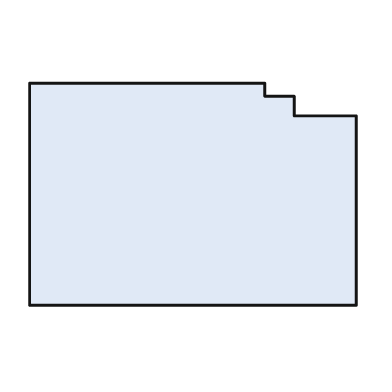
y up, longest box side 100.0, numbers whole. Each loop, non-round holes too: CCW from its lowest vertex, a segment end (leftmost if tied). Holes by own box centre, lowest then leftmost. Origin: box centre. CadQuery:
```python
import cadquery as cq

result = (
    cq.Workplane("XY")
    .moveTo(-50.0, -34.0)
    .lineTo(50.0, -34.0)
    .lineTo(50.0, 24.0)
    .lineTo(31.0, 24.0)
    .lineTo(31.0, 30.0)
    .lineTo(22.0, 30.0)
    .lineTo(22.0, 34.0)
    .lineTo(-50.0, 34.0)
    .close()
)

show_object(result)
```